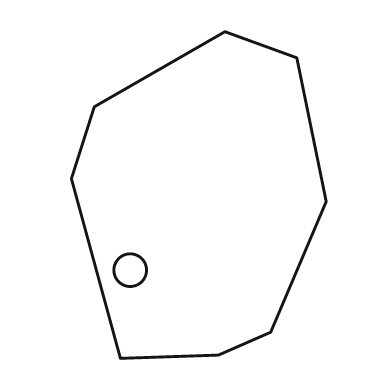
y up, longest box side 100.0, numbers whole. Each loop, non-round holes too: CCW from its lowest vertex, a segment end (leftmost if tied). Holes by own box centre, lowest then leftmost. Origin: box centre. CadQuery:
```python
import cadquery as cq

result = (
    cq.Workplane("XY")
    .moveTo(-24.0, -50.0)
    .lineTo(6.0, -49.0)
    .lineTo(22.0, -42.0)
    .lineTo(39.0, -2.0)
    .lineTo(30.0, 42.0)
    .lineTo(8.0, 50.0)
    .lineTo(-32.0, 27.0)
    .lineTo(-39.0, 5.0)
    .close()
    .moveTo(-21.0, -23.0)
    .circle(5.0)
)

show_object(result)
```